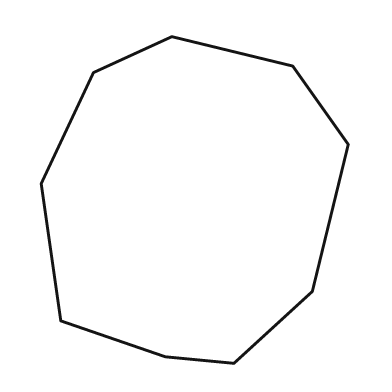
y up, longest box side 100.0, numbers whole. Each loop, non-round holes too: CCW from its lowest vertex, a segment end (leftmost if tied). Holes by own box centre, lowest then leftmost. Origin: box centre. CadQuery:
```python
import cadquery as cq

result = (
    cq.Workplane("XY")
    .moveTo(12.0, -50.0)
    .lineTo(36.0, -28.0)
    .lineTo(47.0, 17.0)
    .lineTo(30.0, 41.0)
    .lineTo(-7.0, 50.0)
    .lineTo(-31.0, 39.0)
    .lineTo(-47.0, 5.0)
    .lineTo(-41.0, -37.0)
    .lineTo(-9.0, -48.0)
    .close()
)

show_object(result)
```